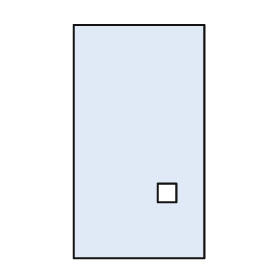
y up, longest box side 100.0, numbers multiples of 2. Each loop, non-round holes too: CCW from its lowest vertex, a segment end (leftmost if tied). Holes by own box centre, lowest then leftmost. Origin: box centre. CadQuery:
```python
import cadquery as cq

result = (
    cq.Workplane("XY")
    .moveTo(-28.0, -50.0)
    .lineTo(28.0, -50.0)
    .lineTo(28.0, 50.0)
    .lineTo(-28.0, 50.0)
    .close()
    .moveTo(8.0, -26.0)
    .lineTo(16.0, -26.0)
    .lineTo(16.0, -18.0)
    .lineTo(8.0, -18.0)
    .close()
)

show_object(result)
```